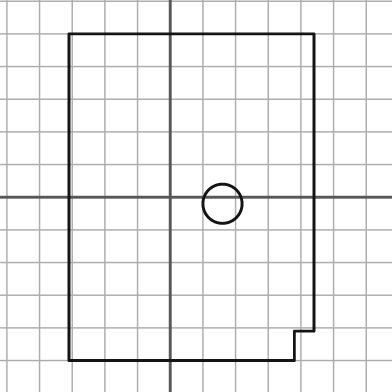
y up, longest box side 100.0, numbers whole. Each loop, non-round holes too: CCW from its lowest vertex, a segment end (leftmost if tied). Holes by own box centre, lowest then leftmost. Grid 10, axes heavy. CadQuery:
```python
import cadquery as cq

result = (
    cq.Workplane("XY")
    .moveTo(-31.0, -50.0)
    .lineTo(38.0, -50.0)
    .lineTo(38.0, -41.0)
    .lineTo(44.0, -41.0)
    .lineTo(44.0, 50.0)
    .lineTo(-31.0, 50.0)
    .close()
    .moveTo(16.0, -2.0)
    .circle(6.0)
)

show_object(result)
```